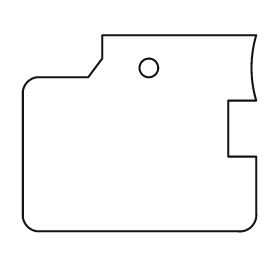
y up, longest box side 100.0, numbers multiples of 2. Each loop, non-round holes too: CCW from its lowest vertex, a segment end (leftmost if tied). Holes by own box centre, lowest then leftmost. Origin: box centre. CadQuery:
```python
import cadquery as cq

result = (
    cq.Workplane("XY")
    .moveTo(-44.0, -42.0)
    .lineTo(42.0, -42.0)
    .threePointArc((48.0, -40.0), (50.0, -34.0))
    .lineTo(50.0, -10.0)
    .lineTo(38.0, -10.0)
    .lineTo(38.0, 14.0)
    .lineTo(50.0, 14.0)
    .threePointArc((48.0, 28.0), (50.0, 42.0))
    .lineTo(-16.0, 42.0)
    .lineTo(-16.0, 32.0)
    .lineTo(-22.0, 24.0)
    .lineTo(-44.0, 24.0)
    .threePointArc((-48.0, 22.0), (-50.0, 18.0))
    .lineTo(-50.0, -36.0)
    .threePointArc((-48.0, -40.0), (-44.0, -42.0))
    .close()
    .moveTo(4.0, 28.0)
    .circle(4.0)
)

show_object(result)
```